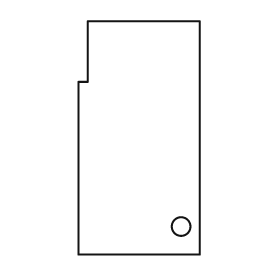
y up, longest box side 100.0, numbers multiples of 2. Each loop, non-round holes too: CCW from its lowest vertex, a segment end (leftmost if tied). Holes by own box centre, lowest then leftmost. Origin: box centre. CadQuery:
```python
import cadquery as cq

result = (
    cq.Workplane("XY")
    .moveTo(-26.0, -50.0)
    .lineTo(26.0, -50.0)
    .lineTo(26.0, 50.0)
    .lineTo(-22.0, 50.0)
    .lineTo(-22.0, 24.0)
    .lineTo(-26.0, 24.0)
    .close()
    .moveTo(18.0, -38.0)
    .circle(4.0)
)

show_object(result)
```